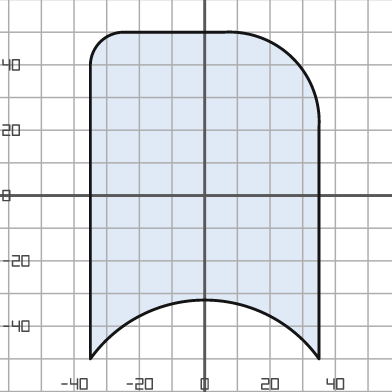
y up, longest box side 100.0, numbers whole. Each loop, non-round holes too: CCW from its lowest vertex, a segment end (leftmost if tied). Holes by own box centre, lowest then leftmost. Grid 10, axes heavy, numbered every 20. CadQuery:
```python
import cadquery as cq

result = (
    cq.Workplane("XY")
    .moveTo(-35.0, -50.0)
    .threePointArc((0.0, -32.0), (35.0, -50.0))
    .lineTo(35.0, 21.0)
    .threePointArc((27.0, 42.0), (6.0, 50.0))
    .lineTo(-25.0, 50.0)
    .threePointArc((-32.0, 47.0), (-35.0, 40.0))
    .close()
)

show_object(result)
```